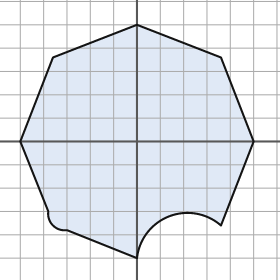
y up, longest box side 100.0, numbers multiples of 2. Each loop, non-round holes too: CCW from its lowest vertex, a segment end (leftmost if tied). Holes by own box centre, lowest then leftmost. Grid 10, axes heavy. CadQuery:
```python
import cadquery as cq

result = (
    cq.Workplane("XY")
    .moveTo(0.0, -50.0)
    .threePointArc((14.0, -32.0), (36.0, -36.0))
    .lineTo(50.0, 0.0)
    .lineTo(36.0, 36.0)
    .lineTo(0.0, 50.0)
    .lineTo(-36.0, 36.0)
    .lineTo(-50.0, 0.0)
    .lineTo(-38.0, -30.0)
    .threePointArc((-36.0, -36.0), (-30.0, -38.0))
    .close()
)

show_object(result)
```